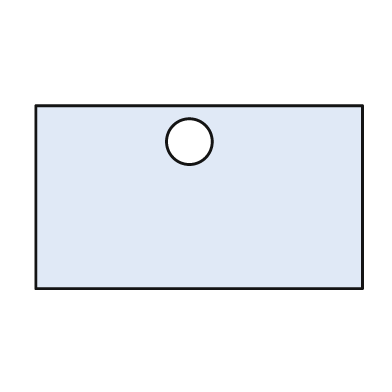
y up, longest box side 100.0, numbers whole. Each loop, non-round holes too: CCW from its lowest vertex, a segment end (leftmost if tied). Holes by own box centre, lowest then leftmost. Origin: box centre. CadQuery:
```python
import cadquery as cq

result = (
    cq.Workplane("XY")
    .moveTo(-50.0, -28.0)
    .lineTo(50.0, -28.0)
    .lineTo(50.0, 28.0)
    .lineTo(-50.0, 28.0)
    .close()
    .moveTo(-3.0, 17.0)
    .circle(7.0)
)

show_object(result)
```